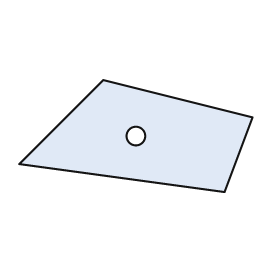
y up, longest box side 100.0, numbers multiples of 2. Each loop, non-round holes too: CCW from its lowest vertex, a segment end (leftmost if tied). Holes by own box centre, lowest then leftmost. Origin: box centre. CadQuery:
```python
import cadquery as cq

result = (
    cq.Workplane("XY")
    .moveTo(38.0, -24.0)
    .lineTo(50.0, 8.0)
    .lineTo(-14.0, 24.0)
    .lineTo(-50.0, -12.0)
    .close()
    .moveTo(0.0, 0.0)
    .circle(4.0)
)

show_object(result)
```